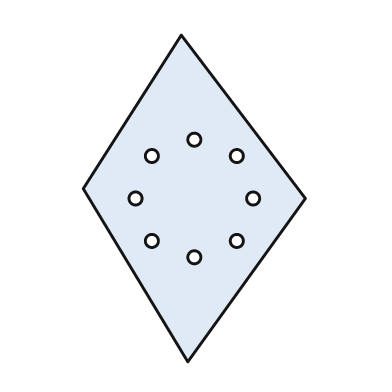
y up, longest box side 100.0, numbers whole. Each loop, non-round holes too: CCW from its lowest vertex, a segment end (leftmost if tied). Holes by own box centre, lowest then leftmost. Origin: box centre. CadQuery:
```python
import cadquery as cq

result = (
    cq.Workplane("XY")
    .moveTo(-2.0, -50.0)
    .lineTo(34.0, 0.0)
    .lineTo(-4.0, 50.0)
    .lineTo(-34.0, 3.0)
    .close()
    .moveTo(0.0, -18.0)
    .circle(2.0)
    .moveTo(-13.0, -13.0)
    .circle(2.0)
    .moveTo(13.0, -13.0)
    .circle(2.0)
    .moveTo(-18.0, 0.0)
    .circle(2.0)
    .moveTo(18.0, 0.0)
    .circle(2.0)
    .moveTo(-13.0, 13.0)
    .circle(2.0)
    .moveTo(13.0, 13.0)
    .circle(2.0)
    .moveTo(0.0, 18.0)
    .circle(2.0)
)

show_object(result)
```